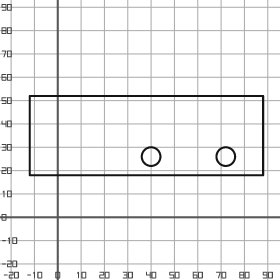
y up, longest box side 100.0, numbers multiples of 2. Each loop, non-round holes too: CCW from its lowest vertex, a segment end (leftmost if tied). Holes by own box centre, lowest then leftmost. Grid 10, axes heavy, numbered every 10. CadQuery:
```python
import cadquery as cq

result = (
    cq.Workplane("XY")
    .moveTo(-12.0, 18.0)
    .lineTo(88.0, 18.0)
    .lineTo(88.0, 52.0)
    .lineTo(-12.0, 52.0)
    .close()
    .moveTo(40.0, 26.0)
    .circle(4.0)
    .moveTo(72.0, 26.0)
    .circle(4.0)
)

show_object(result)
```